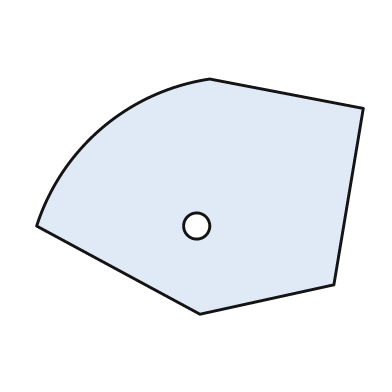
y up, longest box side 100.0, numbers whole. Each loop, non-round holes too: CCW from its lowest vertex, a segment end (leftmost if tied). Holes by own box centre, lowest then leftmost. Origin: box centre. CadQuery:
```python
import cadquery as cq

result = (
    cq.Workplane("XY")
    .moveTo(0.0, -36.0)
    .lineTo(41.0, -27.0)
    .lineTo(50.0, 27.0)
    .lineTo(3.0, 36.0)
    .threePointArc((-30.0, 21.0), (-50.0, -9.0))
    .close()
    .moveTo(-1.0, -9.0)
    .circle(4.0)
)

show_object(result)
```